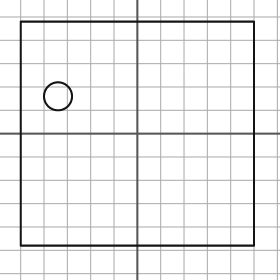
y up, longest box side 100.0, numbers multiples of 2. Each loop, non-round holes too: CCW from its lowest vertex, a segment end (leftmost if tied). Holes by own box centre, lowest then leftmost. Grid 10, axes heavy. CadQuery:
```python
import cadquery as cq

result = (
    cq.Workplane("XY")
    .moveTo(-50.0, -48.0)
    .lineTo(50.0, -48.0)
    .lineTo(50.0, 48.0)
    .lineTo(-50.0, 48.0)
    .close()
    .moveTo(-34.0, 16.0)
    .circle(6.0)
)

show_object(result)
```